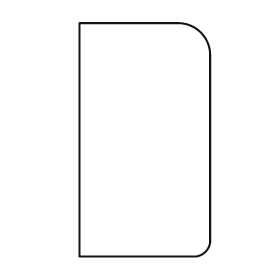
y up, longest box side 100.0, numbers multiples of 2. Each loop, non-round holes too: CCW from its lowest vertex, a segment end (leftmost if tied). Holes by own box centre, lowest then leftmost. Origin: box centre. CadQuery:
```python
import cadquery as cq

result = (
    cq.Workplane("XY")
    .moveTo(-28.0, -50.0)
    .lineTo(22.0, -50.0)
    .threePointArc((26.0, -48.0), (28.0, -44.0))
    .lineTo(28.0, 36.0)
    .threePointArc((24.0, 46.0), (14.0, 50.0))
    .lineTo(-28.0, 50.0)
    .close()
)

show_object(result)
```